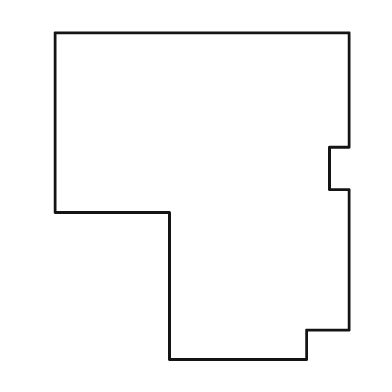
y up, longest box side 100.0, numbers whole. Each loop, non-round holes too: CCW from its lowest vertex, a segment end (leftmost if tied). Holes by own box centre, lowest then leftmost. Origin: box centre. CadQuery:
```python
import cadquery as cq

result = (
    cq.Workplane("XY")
    .moveTo(-10.0, -50.0)
    .lineTo(32.0, -50.0)
    .lineTo(32.0, -41.0)
    .lineTo(45.0, -41.0)
    .lineTo(45.0, 2.0)
    .lineTo(39.0, 2.0)
    .lineTo(39.0, 15.0)
    .lineTo(45.0, 15.0)
    .lineTo(45.0, 50.0)
    .lineTo(-45.0, 50.0)
    .lineTo(-45.0, -5.0)
    .lineTo(-10.0, -5.0)
    .close()
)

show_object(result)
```